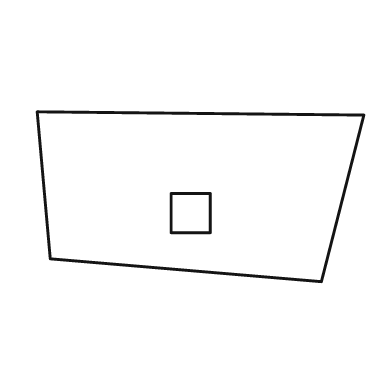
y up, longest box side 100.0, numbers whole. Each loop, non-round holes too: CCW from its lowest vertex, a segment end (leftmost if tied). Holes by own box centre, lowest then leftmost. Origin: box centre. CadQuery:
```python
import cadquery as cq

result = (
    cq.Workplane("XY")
    .moveTo(37.0, -26.0)
    .lineTo(50.0, 25.0)
    .lineTo(-50.0, 26.0)
    .lineTo(-46.0, -19.0)
    .close()
    .moveTo(-9.0, -11.0)
    .lineTo(3.0, -11.0)
    .lineTo(3.0, 1.0)
    .lineTo(-9.0, 1.0)
    .close()
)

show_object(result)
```